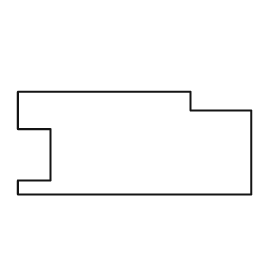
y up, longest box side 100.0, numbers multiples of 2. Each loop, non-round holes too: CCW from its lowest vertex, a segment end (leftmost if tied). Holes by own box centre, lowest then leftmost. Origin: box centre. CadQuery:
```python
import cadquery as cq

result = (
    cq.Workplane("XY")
    .moveTo(-50.0, -22.0)
    .lineTo(50.0, -22.0)
    .lineTo(50.0, 14.0)
    .lineTo(24.0, 14.0)
    .lineTo(24.0, 22.0)
    .lineTo(-50.0, 22.0)
    .lineTo(-50.0, 6.0)
    .lineTo(-36.0, 6.0)
    .lineTo(-36.0, -16.0)
    .lineTo(-50.0, -16.0)
    .close()
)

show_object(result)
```